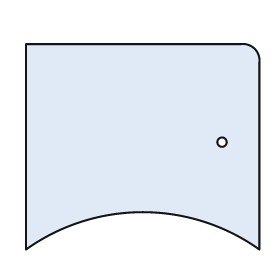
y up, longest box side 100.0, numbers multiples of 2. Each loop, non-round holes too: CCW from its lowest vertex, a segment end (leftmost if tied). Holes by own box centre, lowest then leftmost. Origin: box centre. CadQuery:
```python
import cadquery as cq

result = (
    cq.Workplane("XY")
    .moveTo(-50.0, -44.0)
    .threePointArc((0.0, -28.0), (50.0, -44.0))
    .lineTo(50.0, 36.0)
    .threePointArc((48.0, 42.0), (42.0, 44.0))
    .lineTo(-50.0, 44.0)
    .close()
    .moveTo(34.0, 2.0)
    .circle(2.0)
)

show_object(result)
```